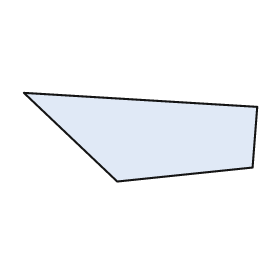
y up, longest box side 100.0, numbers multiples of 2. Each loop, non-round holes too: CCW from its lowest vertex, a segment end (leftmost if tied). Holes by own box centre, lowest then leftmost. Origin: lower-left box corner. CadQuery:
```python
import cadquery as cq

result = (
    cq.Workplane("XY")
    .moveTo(40.0, 0.0)
    .lineTo(98.0, 6.0)
    .lineTo(100.0, 32.0)
    .lineTo(0.0, 38.0)
    .close()
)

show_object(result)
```